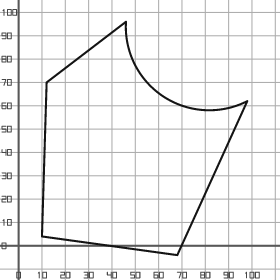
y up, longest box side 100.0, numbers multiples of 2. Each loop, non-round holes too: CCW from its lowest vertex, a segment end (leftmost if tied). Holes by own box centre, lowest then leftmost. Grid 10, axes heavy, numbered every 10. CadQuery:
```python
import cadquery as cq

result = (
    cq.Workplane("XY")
    .moveTo(68.0, -4.0)
    .lineTo(98.0, 62.0)
    .threePointArc((62.0, 64.0), (46.0, 96.0))
    .lineTo(12.0, 70.0)
    .lineTo(10.0, 4.0)
    .close()
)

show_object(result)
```